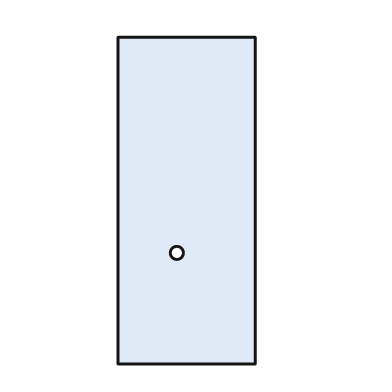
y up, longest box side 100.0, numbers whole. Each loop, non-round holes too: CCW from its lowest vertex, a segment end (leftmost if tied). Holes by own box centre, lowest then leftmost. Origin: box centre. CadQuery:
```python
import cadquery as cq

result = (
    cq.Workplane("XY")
    .moveTo(-21.0, -50.0)
    .lineTo(21.0, -50.0)
    .lineTo(21.0, 50.0)
    .lineTo(-21.0, 50.0)
    .close()
    .moveTo(-3.0, -16.0)
    .circle(2.0)
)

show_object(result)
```